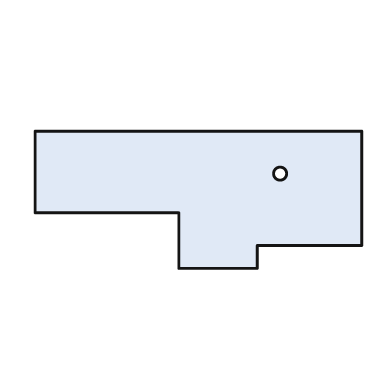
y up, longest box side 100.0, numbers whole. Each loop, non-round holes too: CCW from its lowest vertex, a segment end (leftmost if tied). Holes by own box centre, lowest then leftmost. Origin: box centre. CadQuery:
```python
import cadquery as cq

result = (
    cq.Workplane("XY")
    .moveTo(-6.0, -21.0)
    .lineTo(18.0, -21.0)
    .lineTo(18.0, -14.0)
    .lineTo(50.0, -14.0)
    .lineTo(50.0, 21.0)
    .lineTo(-50.0, 21.0)
    .lineTo(-50.0, -4.0)
    .lineTo(-6.0, -4.0)
    .close()
    .moveTo(25.0, 8.0)
    .circle(2.0)
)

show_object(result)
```